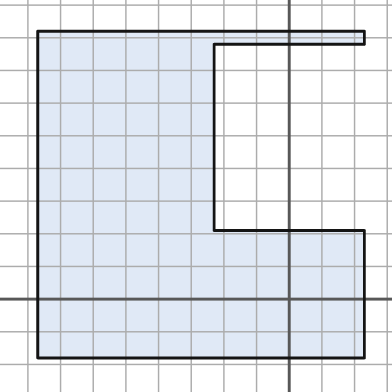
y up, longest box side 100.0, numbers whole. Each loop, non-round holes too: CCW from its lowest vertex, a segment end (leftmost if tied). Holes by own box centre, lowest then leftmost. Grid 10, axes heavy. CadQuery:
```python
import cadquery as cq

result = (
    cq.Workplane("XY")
    .moveTo(-77.0, -18.0)
    .lineTo(23.0, -18.0)
    .lineTo(23.0, 21.0)
    .lineTo(-23.0, 21.0)
    .lineTo(-23.0, 78.0)
    .lineTo(23.0, 78.0)
    .lineTo(23.0, 82.0)
    .lineTo(-77.0, 82.0)
    .close()
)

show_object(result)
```